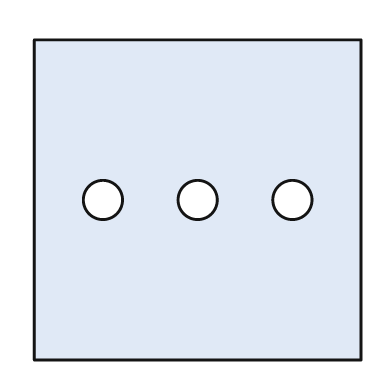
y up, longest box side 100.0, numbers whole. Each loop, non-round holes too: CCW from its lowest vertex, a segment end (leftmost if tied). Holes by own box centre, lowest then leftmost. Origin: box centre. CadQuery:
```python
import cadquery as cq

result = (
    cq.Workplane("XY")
    .moveTo(-50.0, -49.0)
    .lineTo(50.0, -49.0)
    .lineTo(50.0, 49.0)
    .lineTo(-50.0, 49.0)
    .close()
    .moveTo(-29.0, 0.0)
    .circle(6.0)
    .moveTo(0.0, 0.0)
    .circle(6.0)
    .moveTo(29.0, 0.0)
    .circle(6.0)
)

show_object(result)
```